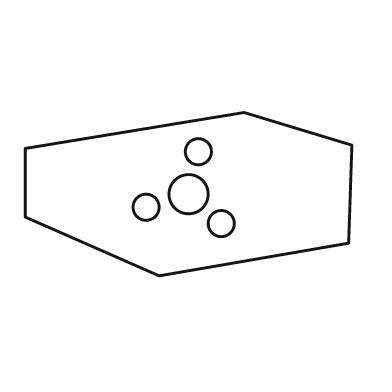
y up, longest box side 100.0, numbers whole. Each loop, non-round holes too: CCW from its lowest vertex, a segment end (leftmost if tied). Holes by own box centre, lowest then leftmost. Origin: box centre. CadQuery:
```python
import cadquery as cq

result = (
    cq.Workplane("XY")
    .moveTo(-9.0, -25.0)
    .lineTo(49.0, -15.0)
    .lineTo(50.0, 15.0)
    .lineTo(17.0, 25.0)
    .lineTo(-50.0, 14.0)
    .lineTo(-50.0, -7.0)
    .close()
    .moveTo(10.0, -9.0)
    .circle(4.0)
    .moveTo(-13.0, -4.0)
    .circle(4.0)
    .moveTo(0.0, 0.0)
    .circle(6.0)
    .moveTo(3.0, 13.0)
    .circle(4.0)
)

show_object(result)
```